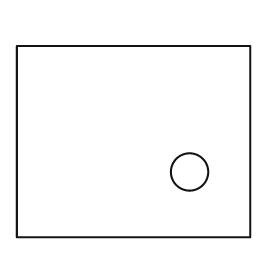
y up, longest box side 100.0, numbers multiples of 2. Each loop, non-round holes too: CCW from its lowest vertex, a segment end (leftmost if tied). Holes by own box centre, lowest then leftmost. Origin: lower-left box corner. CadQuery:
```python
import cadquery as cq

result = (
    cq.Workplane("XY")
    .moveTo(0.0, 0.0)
    .lineTo(100.0, 0.0)
    .lineTo(100.0, 82.0)
    .lineTo(0.0, 82.0)
    .close()
    .moveTo(74.0, 28.0)
    .circle(8.0)
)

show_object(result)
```